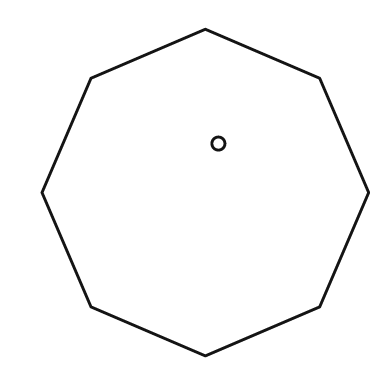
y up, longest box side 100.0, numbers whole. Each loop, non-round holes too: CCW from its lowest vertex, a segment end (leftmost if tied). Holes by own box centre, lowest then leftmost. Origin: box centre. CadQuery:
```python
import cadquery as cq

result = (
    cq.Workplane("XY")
    .moveTo(0.0, -50.0)
    .lineTo(35.0, -35.0)
    .lineTo(50.0, 0.0)
    .lineTo(35.0, 35.0)
    .lineTo(0.0, 50.0)
    .lineTo(-35.0, 35.0)
    .lineTo(-50.0, 0.0)
    .lineTo(-35.0, -35.0)
    .close()
    .moveTo(4.0, 15.0)
    .circle(2.0)
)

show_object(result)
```